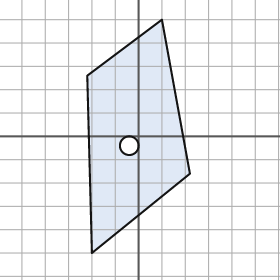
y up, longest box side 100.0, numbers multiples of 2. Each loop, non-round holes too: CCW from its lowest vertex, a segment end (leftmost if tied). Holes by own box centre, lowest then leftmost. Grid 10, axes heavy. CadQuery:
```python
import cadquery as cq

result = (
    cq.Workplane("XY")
    .moveTo(-20.0, -50.0)
    .lineTo(22.0, -16.0)
    .lineTo(10.0, 50.0)
    .lineTo(-22.0, 26.0)
    .close()
    .moveTo(-4.0, -4.0)
    .circle(4.0)
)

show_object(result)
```